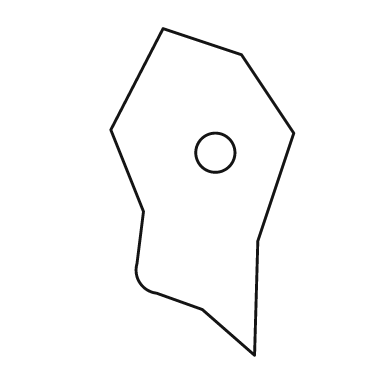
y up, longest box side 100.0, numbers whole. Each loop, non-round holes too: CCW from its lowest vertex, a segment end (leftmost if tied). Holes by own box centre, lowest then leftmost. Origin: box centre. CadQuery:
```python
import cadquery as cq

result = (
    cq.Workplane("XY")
    .moveTo(16.0, -50.0)
    .lineTo(17.0, -15.0)
    .lineTo(28.0, 18.0)
    .lineTo(12.0, 42.0)
    .lineTo(-12.0, 50.0)
    .lineTo(-28.0, 19.0)
    .lineTo(-18.0, -6.0)
    .lineTo(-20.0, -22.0)
    .threePointArc((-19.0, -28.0), (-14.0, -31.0))
    .lineTo(0.0, -36.0)
    .close()
    .moveTo(4.0, 12.0)
    .circle(6.0)
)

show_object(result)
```